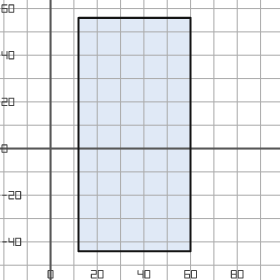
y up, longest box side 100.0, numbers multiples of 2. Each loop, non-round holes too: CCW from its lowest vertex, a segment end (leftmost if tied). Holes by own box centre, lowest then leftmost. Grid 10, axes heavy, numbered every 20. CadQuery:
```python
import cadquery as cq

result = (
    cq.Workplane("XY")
    .moveTo(12.0, -44.0)
    .lineTo(60.0, -44.0)
    .lineTo(60.0, 56.0)
    .lineTo(12.0, 56.0)
    .close()
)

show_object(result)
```